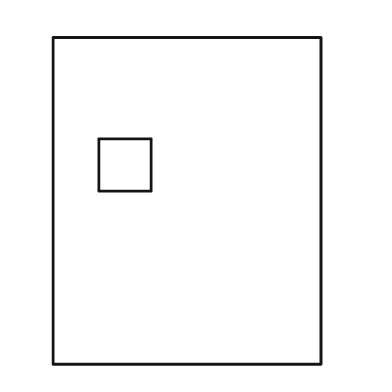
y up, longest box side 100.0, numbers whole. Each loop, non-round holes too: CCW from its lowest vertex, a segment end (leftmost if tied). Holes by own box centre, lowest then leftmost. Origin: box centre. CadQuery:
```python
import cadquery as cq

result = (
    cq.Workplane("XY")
    .moveTo(-41.0, -50.0)
    .lineTo(41.0, -50.0)
    .lineTo(41.0, 50.0)
    .lineTo(-41.0, 50.0)
    .close()
    .moveTo(-27.0, 3.0)
    .lineTo(-11.0, 3.0)
    .lineTo(-11.0, 19.0)
    .lineTo(-27.0, 19.0)
    .close()
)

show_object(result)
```